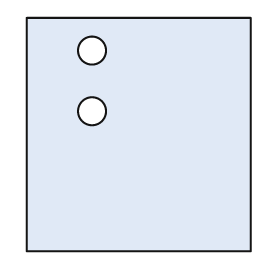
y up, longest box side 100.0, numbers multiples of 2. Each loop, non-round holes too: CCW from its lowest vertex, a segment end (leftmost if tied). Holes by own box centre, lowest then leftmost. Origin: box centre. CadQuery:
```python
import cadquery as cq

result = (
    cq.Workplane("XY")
    .moveTo(-48.0, -50.0)
    .lineTo(48.0, -50.0)
    .lineTo(48.0, 50.0)
    .lineTo(-48.0, 50.0)
    .close()
    .moveTo(-20.0, 10.0)
    .circle(6.0)
    .moveTo(-20.0, 36.0)
    .circle(6.0)
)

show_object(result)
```